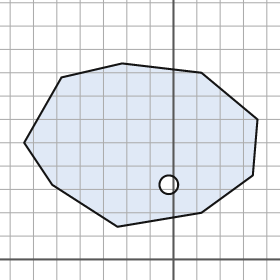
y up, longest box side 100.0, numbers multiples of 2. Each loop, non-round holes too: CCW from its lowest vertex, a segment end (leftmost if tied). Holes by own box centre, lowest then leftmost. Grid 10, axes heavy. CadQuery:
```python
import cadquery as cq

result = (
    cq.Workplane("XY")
    .moveTo(-24.0, 14.0)
    .lineTo(12.0, 20.0)
    .lineTo(34.0, 36.0)
    .lineTo(36.0, 60.0)
    .lineTo(12.0, 80.0)
    .lineTo(-22.0, 84.0)
    .lineTo(-48.0, 78.0)
    .lineTo(-64.0, 50.0)
    .lineTo(-52.0, 32.0)
    .close()
    .moveTo(-2.0, 32.0)
    .circle(4.0)
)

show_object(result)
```